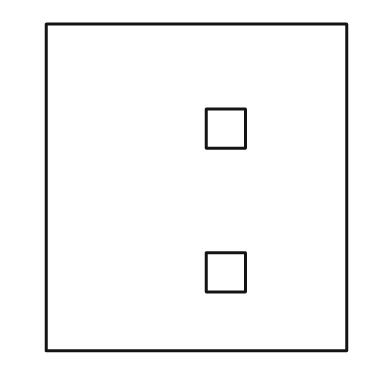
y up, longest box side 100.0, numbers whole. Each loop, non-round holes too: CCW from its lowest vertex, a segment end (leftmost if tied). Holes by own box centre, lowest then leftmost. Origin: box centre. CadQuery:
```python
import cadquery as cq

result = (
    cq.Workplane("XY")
    .moveTo(-46.0, -50.0)
    .lineTo(46.0, -50.0)
    .lineTo(46.0, 50.0)
    .lineTo(-46.0, 50.0)
    .close()
    .moveTo(3.0, -32.0)
    .lineTo(15.0, -32.0)
    .lineTo(15.0, -20.0)
    .lineTo(3.0, -20.0)
    .close()
    .moveTo(3.0, 12.0)
    .lineTo(15.0, 12.0)
    .lineTo(15.0, 24.0)
    .lineTo(3.0, 24.0)
    .close()
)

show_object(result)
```